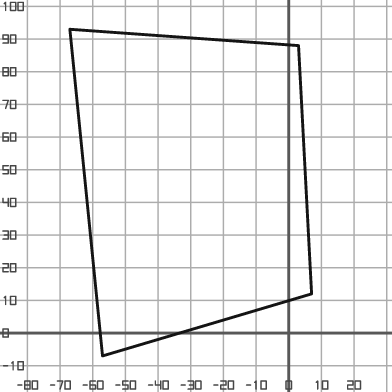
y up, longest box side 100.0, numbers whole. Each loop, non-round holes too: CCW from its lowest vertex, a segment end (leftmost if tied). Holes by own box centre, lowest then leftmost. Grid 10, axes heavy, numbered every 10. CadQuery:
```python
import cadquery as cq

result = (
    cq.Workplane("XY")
    .moveTo(-57.0, -7.0)
    .lineTo(7.0, 12.0)
    .lineTo(3.0, 88.0)
    .lineTo(-67.0, 93.0)
    .close()
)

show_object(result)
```